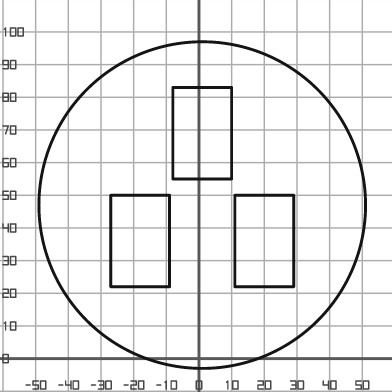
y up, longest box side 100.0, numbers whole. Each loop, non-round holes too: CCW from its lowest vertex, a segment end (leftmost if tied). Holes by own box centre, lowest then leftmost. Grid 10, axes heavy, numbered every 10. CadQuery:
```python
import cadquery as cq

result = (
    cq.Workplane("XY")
    .moveTo(1.0, 47.0)
    .circle(50.0)
    .moveTo(-27.0, 22.0)
    .lineTo(-9.0, 22.0)
    .lineTo(-9.0, 50.0)
    .lineTo(-27.0, 50.0)
    .close()
    .moveTo(11.0, 22.0)
    .lineTo(29.0, 22.0)
    .lineTo(29.0, 50.0)
    .lineTo(11.0, 50.0)
    .close()
    .moveTo(-8.0, 55.0)
    .lineTo(10.0, 55.0)
    .lineTo(10.0, 83.0)
    .lineTo(-8.0, 83.0)
    .close()
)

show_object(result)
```